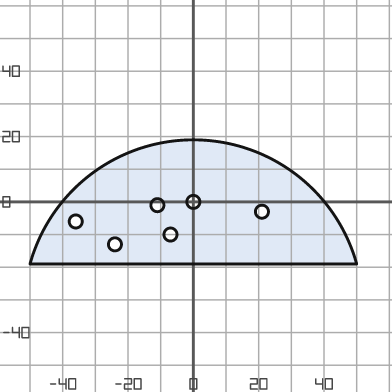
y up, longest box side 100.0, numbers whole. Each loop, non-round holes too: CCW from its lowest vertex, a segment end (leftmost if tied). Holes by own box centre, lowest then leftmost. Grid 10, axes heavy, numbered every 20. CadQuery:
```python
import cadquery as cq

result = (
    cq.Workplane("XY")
    .moveTo(-50.0, -19.0)
    .lineTo(50.0, -19.0)
    .threePointArc((0.0, 19.0), (-50.0, -19.0))
    .close()
    .moveTo(-24.0, -13.0)
    .circle(2.0)
    .moveTo(-7.0, -10.0)
    .circle(2.0)
    .moveTo(-36.0, -6.0)
    .circle(2.0)
    .moveTo(21.0, -3.0)
    .circle(2.0)
    .moveTo(-11.0, -1.0)
    .circle(2.0)
    .moveTo(0.0, 0.0)
    .circle(2.0)
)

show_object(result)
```